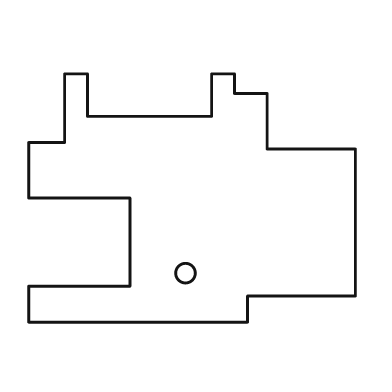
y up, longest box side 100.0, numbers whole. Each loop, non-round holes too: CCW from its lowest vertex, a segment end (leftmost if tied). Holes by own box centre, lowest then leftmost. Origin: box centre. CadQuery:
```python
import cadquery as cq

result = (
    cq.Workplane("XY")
    .moveTo(-50.0, -38.0)
    .lineTo(17.0, -38.0)
    .lineTo(17.0, -30.0)
    .lineTo(50.0, -30.0)
    .lineTo(50.0, 15.0)
    .lineTo(23.0, 15.0)
    .lineTo(23.0, 32.0)
    .lineTo(13.0, 32.0)
    .lineTo(13.0, 38.0)
    .lineTo(6.0, 38.0)
    .lineTo(6.0, 25.0)
    .lineTo(-32.0, 25.0)
    .lineTo(-32.0, 38.0)
    .lineTo(-39.0, 38.0)
    .lineTo(-39.0, 17.0)
    .lineTo(-50.0, 17.0)
    .lineTo(-50.0, 0.0)
    .lineTo(-19.0, 0.0)
    .lineTo(-19.0, -27.0)
    .lineTo(-50.0, -27.0)
    .close()
    .moveTo(-2.0, -23.0)
    .circle(3.0)
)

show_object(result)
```